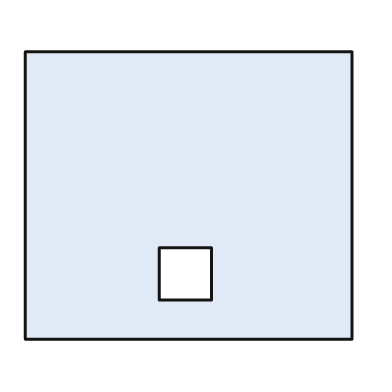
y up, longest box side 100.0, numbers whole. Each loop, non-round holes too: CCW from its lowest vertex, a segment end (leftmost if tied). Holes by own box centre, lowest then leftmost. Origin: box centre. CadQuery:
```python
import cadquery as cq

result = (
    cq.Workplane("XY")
    .moveTo(-50.0, -44.0)
    .lineTo(50.0, -44.0)
    .lineTo(50.0, 44.0)
    .lineTo(-50.0, 44.0)
    .close()
    .moveTo(-9.0, -32.0)
    .lineTo(7.0, -32.0)
    .lineTo(7.0, -16.0)
    .lineTo(-9.0, -16.0)
    .close()
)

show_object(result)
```